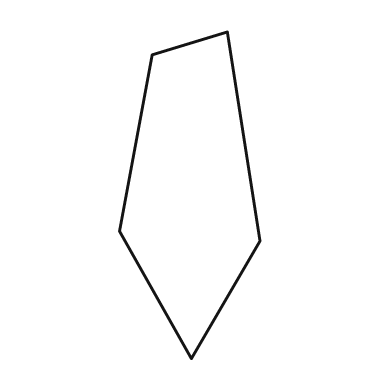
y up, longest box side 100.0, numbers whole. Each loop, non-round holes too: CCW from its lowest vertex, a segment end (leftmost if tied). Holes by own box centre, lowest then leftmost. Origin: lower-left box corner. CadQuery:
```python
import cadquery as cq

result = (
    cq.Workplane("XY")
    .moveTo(22.0, 0.0)
    .lineTo(43.0, 36.0)
    .lineTo(33.0, 100.0)
    .lineTo(10.0, 93.0)
    .lineTo(0.0, 39.0)
    .close()
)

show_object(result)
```